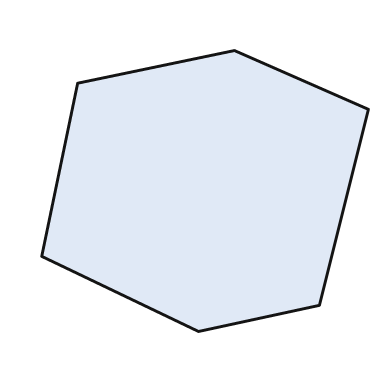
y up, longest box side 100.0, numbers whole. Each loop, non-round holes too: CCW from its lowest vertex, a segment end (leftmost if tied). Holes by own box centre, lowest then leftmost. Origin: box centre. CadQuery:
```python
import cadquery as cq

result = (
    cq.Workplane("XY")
    .moveTo(-2.0, -43.0)
    .lineTo(35.0, -35.0)
    .lineTo(50.0, 25.0)
    .lineTo(9.0, 43.0)
    .lineTo(-39.0, 33.0)
    .lineTo(-50.0, -20.0)
    .close()
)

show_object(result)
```